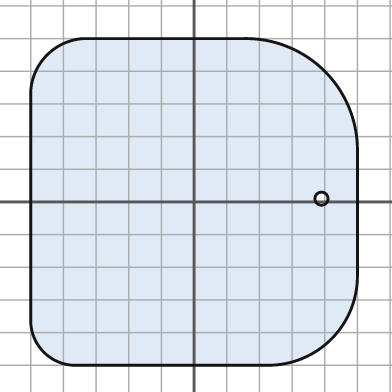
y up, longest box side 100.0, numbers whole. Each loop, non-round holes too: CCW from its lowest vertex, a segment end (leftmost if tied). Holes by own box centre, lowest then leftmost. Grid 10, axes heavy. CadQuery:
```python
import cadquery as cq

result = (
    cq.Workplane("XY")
    .moveTo(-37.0, -50.0)
    .lineTo(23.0, -50.0)
    .threePointArc((42.0, -42.0), (50.0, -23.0))
    .lineTo(50.0, 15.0)
    .threePointArc((40.0, 40.0), (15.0, 50.0))
    .lineTo(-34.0, 50.0)
    .threePointArc((-45.0, 45.0), (-50.0, 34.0))
    .lineTo(-50.0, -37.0)
    .threePointArc((-46.0, -46.0), (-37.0, -50.0))
    .close()
    .moveTo(39.0, 1.0)
    .circle(2.0)
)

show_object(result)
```